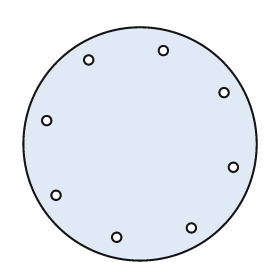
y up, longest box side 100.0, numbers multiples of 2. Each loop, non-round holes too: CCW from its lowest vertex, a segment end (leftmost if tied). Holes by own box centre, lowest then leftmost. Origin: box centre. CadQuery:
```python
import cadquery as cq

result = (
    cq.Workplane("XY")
    .moveTo(0.0, 0.0)
    .circle(50.0)
    .moveTo(-10.0, -40.0)
    .circle(2.0)
    .moveTo(22.0, -36.0)
    .circle(2.0)
    .moveTo(-36.0, -22.0)
    .circle(2.0)
    .moveTo(40.0, -10.0)
    .circle(2.0)
    .moveTo(-40.0, 10.0)
    .circle(2.0)
    .moveTo(36.0, 22.0)
    .circle(2.0)
    .moveTo(-22.0, 36.0)
    .circle(2.0)
    .moveTo(10.0, 40.0)
    .circle(2.0)
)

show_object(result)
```